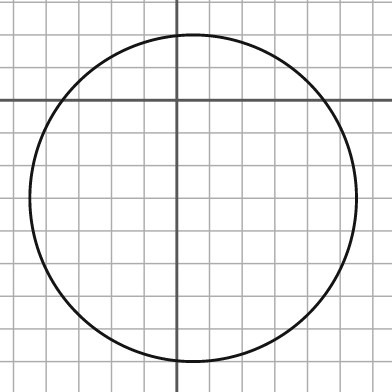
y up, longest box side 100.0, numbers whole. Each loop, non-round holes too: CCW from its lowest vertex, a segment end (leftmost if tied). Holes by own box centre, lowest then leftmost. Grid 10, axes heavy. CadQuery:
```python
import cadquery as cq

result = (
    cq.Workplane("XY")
    .moveTo(5.0, -30.0)
    .circle(50.0)
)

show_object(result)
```